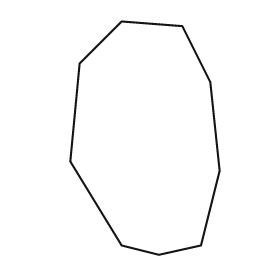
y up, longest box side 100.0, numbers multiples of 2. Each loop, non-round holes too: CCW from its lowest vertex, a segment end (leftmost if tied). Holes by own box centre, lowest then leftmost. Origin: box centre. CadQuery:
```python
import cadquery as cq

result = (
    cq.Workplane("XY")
    .moveTo(6.0, -50.0)
    .lineTo(24.0, -46.0)
    .lineTo(32.0, -14.0)
    .lineTo(28.0, 24.0)
    .lineTo(16.0, 48.0)
    .lineTo(-10.0, 50.0)
    .lineTo(-28.0, 32.0)
    .lineTo(-32.0, -10.0)
    .lineTo(-10.0, -46.0)
    .close()
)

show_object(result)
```